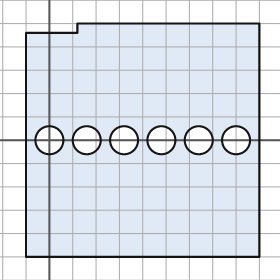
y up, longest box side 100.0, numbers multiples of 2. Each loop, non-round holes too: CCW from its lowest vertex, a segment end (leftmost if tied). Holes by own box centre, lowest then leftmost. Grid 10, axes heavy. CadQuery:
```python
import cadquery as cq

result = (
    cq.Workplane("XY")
    .moveTo(-10.0, -50.0)
    .lineTo(90.0, -50.0)
    .lineTo(90.0, 50.0)
    .lineTo(12.0, 50.0)
    .lineTo(12.0, 46.0)
    .lineTo(-10.0, 46.0)
    .close()
    .moveTo(0.0, 0.0)
    .circle(6.0)
    .moveTo(16.0, 0.0)
    .circle(6.0)
    .moveTo(32.0, 0.0)
    .circle(6.0)
    .moveTo(48.0, 0.0)
    .circle(6.0)
    .moveTo(64.0, 0.0)
    .circle(6.0)
    .moveTo(80.0, 0.0)
    .circle(6.0)
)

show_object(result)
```